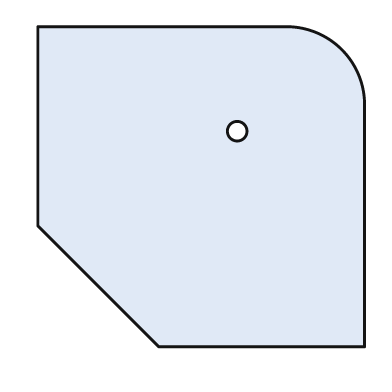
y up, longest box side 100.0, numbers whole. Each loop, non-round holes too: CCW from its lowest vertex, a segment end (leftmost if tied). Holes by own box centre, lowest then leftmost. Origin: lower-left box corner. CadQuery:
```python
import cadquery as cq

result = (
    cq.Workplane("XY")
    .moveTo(37.0, 0.0)
    .lineTo(100.0, 0.0)
    .lineTo(100.0, 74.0)
    .threePointArc((93.0, 91.0), (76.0, 98.0))
    .lineTo(0.0, 98.0)
    .lineTo(0.0, 37.0)
    .close()
    .moveTo(61.0, 66.0)
    .circle(3.0)
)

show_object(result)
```